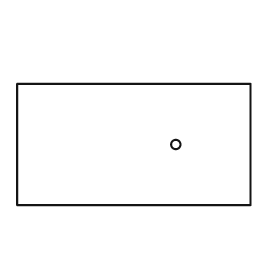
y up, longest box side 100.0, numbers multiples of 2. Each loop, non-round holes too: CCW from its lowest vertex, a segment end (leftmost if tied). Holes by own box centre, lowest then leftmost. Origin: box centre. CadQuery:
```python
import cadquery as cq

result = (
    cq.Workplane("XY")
    .moveTo(-50.0, -26.0)
    .lineTo(50.0, -26.0)
    .lineTo(50.0, 26.0)
    .lineTo(-50.0, 26.0)
    .close()
    .moveTo(18.0, 0.0)
    .circle(2.0)
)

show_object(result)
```